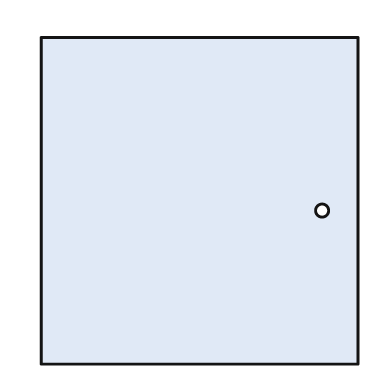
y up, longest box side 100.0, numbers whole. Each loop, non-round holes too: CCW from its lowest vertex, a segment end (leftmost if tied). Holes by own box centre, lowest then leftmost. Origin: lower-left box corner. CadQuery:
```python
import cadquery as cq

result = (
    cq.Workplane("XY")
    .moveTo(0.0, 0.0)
    .lineTo(97.0, 0.0)
    .lineTo(97.0, 100.0)
    .lineTo(0.0, 100.0)
    .close()
    .moveTo(86.0, 47.0)
    .circle(2.0)
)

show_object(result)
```